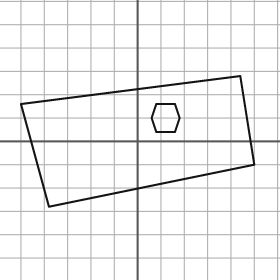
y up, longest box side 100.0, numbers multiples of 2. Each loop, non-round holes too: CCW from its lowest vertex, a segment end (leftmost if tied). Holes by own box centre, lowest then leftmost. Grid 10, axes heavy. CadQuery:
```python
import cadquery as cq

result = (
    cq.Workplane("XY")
    .moveTo(-38.0, -28.0)
    .lineTo(50.0, -10.0)
    .lineTo(44.0, 28.0)
    .lineTo(-50.0, 16.0)
    .close()
    .moveTo(8.0, 4.0)
    .lineTo(16.0, 4.0)
    .lineTo(18.0, 10.0)
    .lineTo(16.0, 16.0)
    .lineTo(8.0, 16.0)
    .lineTo(6.0, 10.0)
    .close()
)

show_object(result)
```